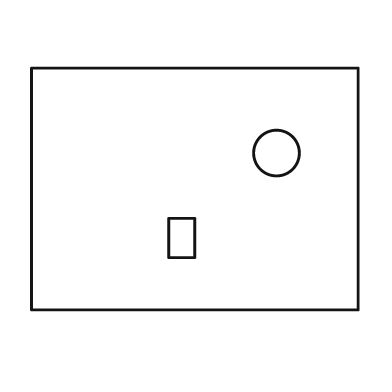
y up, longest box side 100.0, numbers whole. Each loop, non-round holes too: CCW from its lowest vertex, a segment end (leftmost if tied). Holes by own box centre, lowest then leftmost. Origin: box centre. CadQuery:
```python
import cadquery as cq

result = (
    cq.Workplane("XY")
    .moveTo(-50.0, -37.0)
    .lineTo(50.0, -37.0)
    .lineTo(50.0, 37.0)
    .lineTo(-50.0, 37.0)
    .close()
    .moveTo(-8.0, -21.0)
    .lineTo(0.0, -21.0)
    .lineTo(0.0, -9.0)
    .lineTo(-8.0, -9.0)
    .close()
    .moveTo(25.0, 11.0)
    .circle(7.0)
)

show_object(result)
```